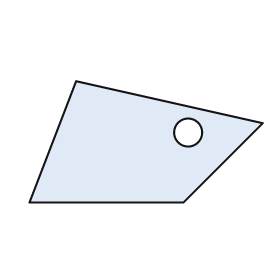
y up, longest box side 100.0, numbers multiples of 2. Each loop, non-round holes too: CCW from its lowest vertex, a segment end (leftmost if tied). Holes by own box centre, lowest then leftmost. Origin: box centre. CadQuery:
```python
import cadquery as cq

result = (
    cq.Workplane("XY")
    .moveTo(-50.0, -26.0)
    .lineTo(16.0, -26.0)
    .lineTo(50.0, 8.0)
    .lineTo(-30.0, 26.0)
    .close()
    .moveTo(18.0, 4.0)
    .circle(6.0)
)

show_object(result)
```